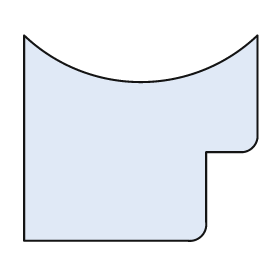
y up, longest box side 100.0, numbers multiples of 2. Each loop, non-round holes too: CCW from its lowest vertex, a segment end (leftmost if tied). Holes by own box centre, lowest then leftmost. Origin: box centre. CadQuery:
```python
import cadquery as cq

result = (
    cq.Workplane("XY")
    .moveTo(-50.0, -44.0)
    .lineTo(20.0, -44.0)
    .threePointArc((26.0, -42.0), (28.0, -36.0))
    .lineTo(28.0, -6.0)
    .lineTo(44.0, -6.0)
    .threePointArc((48.0, -4.0), (50.0, 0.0))
    .lineTo(50.0, 44.0)
    .threePointArc((0.0, 24.0), (-50.0, 44.0))
    .close()
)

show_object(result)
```